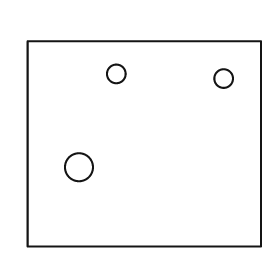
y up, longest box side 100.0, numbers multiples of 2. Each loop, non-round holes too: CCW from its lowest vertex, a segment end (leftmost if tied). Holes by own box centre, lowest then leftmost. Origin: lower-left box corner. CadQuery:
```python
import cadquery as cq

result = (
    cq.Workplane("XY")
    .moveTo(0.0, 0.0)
    .lineTo(100.0, 0.0)
    .lineTo(100.0, 88.0)
    .lineTo(0.0, 88.0)
    .close()
    .moveTo(22.0, 34.0)
    .circle(6.0)
    .moveTo(84.0, 72.0)
    .circle(4.0)
    .moveTo(38.0, 74.0)
    .circle(4.0)
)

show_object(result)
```